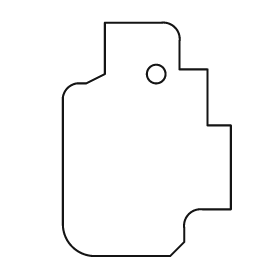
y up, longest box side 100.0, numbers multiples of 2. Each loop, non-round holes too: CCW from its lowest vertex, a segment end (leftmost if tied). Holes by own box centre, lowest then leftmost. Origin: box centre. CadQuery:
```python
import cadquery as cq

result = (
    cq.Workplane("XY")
    .moveTo(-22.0, -50.0)
    .lineTo(10.0, -50.0)
    .lineTo(16.0, -44.0)
    .lineTo(16.0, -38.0)
    .threePointArc((18.0, -32.0), (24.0, -30.0))
    .lineTo(36.0, -30.0)
    .lineTo(36.0, 6.0)
    .lineTo(26.0, 6.0)
    .lineTo(26.0, 30.0)
    .lineTo(14.0, 30.0)
    .lineTo(14.0, 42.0)
    .threePointArc((12.0, 48.0), (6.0, 50.0))
    .lineTo(-18.0, 50.0)
    .lineTo(-18.0, 28.0)
    .lineTo(-26.0, 24.0)
    .lineTo(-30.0, 24.0)
    .threePointArc((-34.0, 22.0), (-36.0, 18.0))
    .lineTo(-36.0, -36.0)
    .threePointArc((-32.0, -46.0), (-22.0, -50.0))
    .close()
    .moveTo(4.0, 28.0)
    .circle(4.0)
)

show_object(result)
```